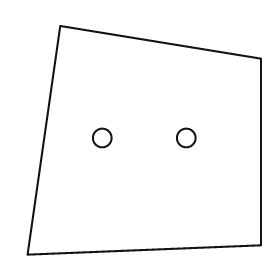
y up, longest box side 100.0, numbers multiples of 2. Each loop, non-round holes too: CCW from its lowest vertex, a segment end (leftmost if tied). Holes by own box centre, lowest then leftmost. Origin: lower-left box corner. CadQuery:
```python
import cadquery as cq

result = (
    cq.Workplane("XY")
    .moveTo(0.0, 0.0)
    .lineTo(100.0, 4.0)
    .lineTo(100.0, 84.0)
    .lineTo(14.0, 98.0)
    .close()
    .moveTo(32.0, 50.0)
    .circle(4.0)
    .moveTo(68.0, 50.0)
    .circle(4.0)
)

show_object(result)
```